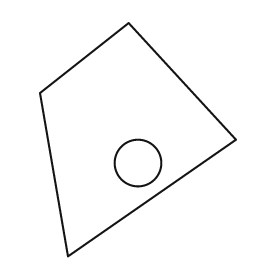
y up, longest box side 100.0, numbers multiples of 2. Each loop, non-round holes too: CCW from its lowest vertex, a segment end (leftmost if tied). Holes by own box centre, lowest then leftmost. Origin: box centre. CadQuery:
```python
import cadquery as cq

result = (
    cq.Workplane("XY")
    .moveTo(-30.0, -50.0)
    .lineTo(42.0, 0.0)
    .lineTo(-4.0, 50.0)
    .lineTo(-42.0, 20.0)
    .close()
    .moveTo(0.0, -10.0)
    .circle(10.0)
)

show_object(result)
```